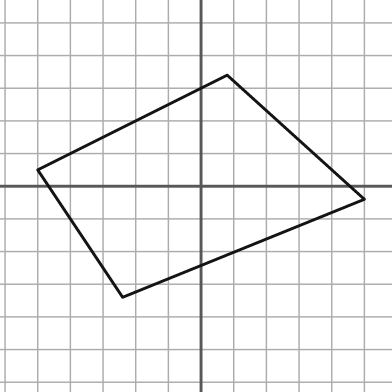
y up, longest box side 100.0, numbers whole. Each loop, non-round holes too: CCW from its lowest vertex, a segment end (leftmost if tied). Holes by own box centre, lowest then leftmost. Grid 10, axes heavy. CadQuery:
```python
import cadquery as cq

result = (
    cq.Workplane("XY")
    .moveTo(-24.0, -34.0)
    .lineTo(50.0, -4.0)
    .lineTo(8.0, 34.0)
    .lineTo(-50.0, 5.0)
    .close()
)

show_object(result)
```